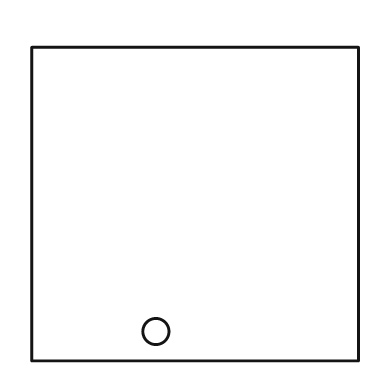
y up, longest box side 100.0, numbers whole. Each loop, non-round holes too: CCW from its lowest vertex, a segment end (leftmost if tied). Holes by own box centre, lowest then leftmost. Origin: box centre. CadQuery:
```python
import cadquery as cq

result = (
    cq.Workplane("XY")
    .moveTo(-50.0, -48.0)
    .lineTo(50.0, -48.0)
    .lineTo(50.0, 48.0)
    .lineTo(-50.0, 48.0)
    .close()
    .moveTo(-12.0, -39.0)
    .circle(4.0)
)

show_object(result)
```